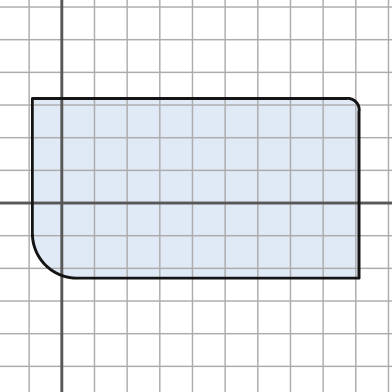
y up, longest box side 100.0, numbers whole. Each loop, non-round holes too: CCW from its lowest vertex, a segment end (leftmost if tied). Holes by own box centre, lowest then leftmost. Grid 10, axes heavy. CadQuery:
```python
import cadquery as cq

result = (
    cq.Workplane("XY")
    .moveTo(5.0, -23.0)
    .lineTo(91.0, -23.0)
    .lineTo(91.0, 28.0)
    .threePointArc((90.0, 31.0), (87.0, 32.0))
    .lineTo(-9.0, 32.0)
    .lineTo(-9.0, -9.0)
    .threePointArc((-5.0, -19.0), (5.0, -23.0))
    .close()
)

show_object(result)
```